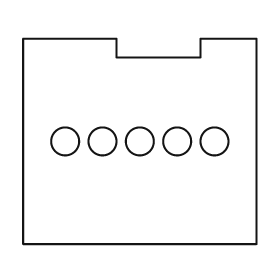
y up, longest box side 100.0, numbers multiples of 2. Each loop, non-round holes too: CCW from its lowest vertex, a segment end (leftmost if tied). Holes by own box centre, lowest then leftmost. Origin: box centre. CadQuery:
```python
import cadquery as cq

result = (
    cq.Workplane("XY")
    .moveTo(-50.0, -44.0)
    .lineTo(50.0, -44.0)
    .lineTo(50.0, 44.0)
    .lineTo(26.0, 44.0)
    .lineTo(26.0, 36.0)
    .lineTo(-10.0, 36.0)
    .lineTo(-10.0, 44.0)
    .lineTo(-50.0, 44.0)
    .close()
    .moveTo(-32.0, 0.0)
    .circle(6.0)
    .moveTo(-16.0, 0.0)
    .circle(6.0)
    .moveTo(0.0, 0.0)
    .circle(6.0)
    .moveTo(16.0, 0.0)
    .circle(6.0)
    .moveTo(32.0, 0.0)
    .circle(6.0)
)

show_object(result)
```